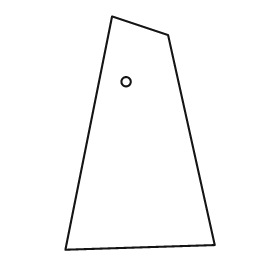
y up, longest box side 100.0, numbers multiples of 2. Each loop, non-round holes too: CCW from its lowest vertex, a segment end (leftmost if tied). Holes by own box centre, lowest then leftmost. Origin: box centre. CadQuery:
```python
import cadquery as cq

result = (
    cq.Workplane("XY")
    .moveTo(-32.0, -50.0)
    .lineTo(32.0, -48.0)
    .lineTo(12.0, 42.0)
    .lineTo(-12.0, 50.0)
    .close()
    .moveTo(-6.0, 22.0)
    .circle(2.0)
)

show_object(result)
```